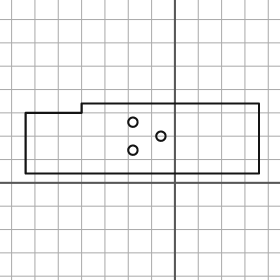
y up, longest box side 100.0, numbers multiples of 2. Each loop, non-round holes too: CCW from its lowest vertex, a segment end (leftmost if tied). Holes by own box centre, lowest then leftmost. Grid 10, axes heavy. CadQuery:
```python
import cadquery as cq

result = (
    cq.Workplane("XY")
    .moveTo(-64.0, 4.0)
    .lineTo(36.0, 4.0)
    .lineTo(36.0, 34.0)
    .lineTo(-40.0, 34.0)
    .lineTo(-40.0, 30.0)
    .lineTo(-64.0, 30.0)
    .close()
    .moveTo(-18.0, 14.0)
    .circle(2.0)
    .moveTo(-6.0, 20.0)
    .circle(2.0)
    .moveTo(-18.0, 26.0)
    .circle(2.0)
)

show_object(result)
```